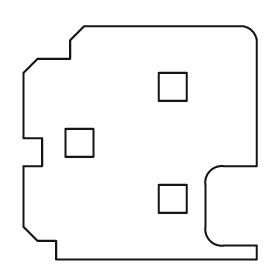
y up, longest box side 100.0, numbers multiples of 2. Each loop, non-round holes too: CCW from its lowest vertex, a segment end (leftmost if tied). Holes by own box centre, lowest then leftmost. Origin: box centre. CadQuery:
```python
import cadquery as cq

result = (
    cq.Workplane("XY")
    .moveTo(-36.0, -50.0)
    .lineTo(50.0, -50.0)
    .lineTo(50.0, -44.0)
    .lineTo(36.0, -44.0)
    .threePointArc((30.0, -42.0), (28.0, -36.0))
    .lineTo(28.0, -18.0)
    .threePointArc((30.0, -12.0), (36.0, -10.0))
    .lineTo(50.0, -10.0)
    .lineTo(50.0, 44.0)
    .threePointArc((48.0, 48.0), (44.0, 50.0))
    .lineTo(-24.0, 50.0)
    .lineTo(-30.0, 44.0)
    .lineTo(-30.0, 36.0)
    .lineTo(-44.0, 36.0)
    .lineTo(-50.0, 30.0)
    .lineTo(-50.0, 2.0)
    .lineTo(-42.0, 2.0)
    .lineTo(-42.0, -10.0)
    .lineTo(-50.0, -10.0)
    .lineTo(-50.0, -36.0)
    .lineTo(-44.0, -42.0)
    .lineTo(-36.0, -42.0)
    .close()
    .moveTo(8.0, -30.0)
    .lineTo(20.0, -30.0)
    .lineTo(20.0, -18.0)
    .lineTo(8.0, -18.0)
    .close()
    .moveTo(-32.0, -6.0)
    .lineTo(-20.0, -6.0)
    .lineTo(-20.0, 6.0)
    .lineTo(-32.0, 6.0)
    .close()
    .moveTo(8.0, 18.0)
    .lineTo(20.0, 18.0)
    .lineTo(20.0, 30.0)
    .lineTo(8.0, 30.0)
    .close()
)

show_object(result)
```